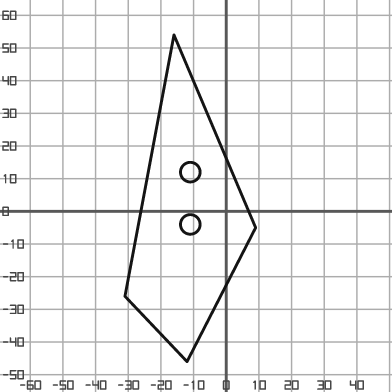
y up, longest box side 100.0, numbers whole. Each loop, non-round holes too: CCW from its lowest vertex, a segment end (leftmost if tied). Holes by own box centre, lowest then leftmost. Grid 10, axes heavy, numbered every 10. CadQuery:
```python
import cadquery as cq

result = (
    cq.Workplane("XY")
    .moveTo(-12.0, -46.0)
    .lineTo(9.0, -5.0)
    .lineTo(-16.0, 54.0)
    .lineTo(-31.0, -26.0)
    .close()
    .moveTo(-11.0, -4.0)
    .circle(3.0)
    .moveTo(-11.0, 12.0)
    .circle(3.0)
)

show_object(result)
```